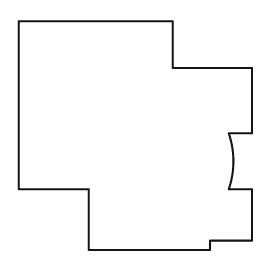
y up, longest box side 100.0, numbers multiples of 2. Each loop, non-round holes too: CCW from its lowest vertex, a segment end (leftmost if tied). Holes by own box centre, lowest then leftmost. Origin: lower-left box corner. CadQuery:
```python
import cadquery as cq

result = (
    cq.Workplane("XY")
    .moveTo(30.0, 0.0)
    .lineTo(82.0, 0.0)
    .lineTo(82.0, 4.0)
    .lineTo(100.0, 4.0)
    .lineTo(100.0, 26.0)
    .lineTo(90.0, 26.0)
    .threePointArc((92.0, 38.0), (90.0, 50.0))
    .lineTo(100.0, 50.0)
    .lineTo(100.0, 78.0)
    .lineTo(66.0, 78.0)
    .lineTo(66.0, 98.0)
    .lineTo(0.0, 98.0)
    .lineTo(0.0, 26.0)
    .lineTo(30.0, 26.0)
    .close()
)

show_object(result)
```